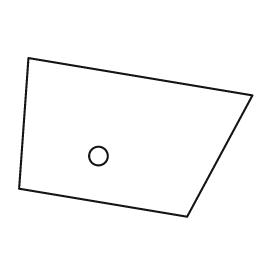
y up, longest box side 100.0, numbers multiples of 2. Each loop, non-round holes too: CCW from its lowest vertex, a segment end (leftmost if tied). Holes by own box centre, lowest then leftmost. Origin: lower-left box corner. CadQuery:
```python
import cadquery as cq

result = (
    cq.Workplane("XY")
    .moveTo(72.0, 0.0)
    .lineTo(100.0, 52.0)
    .lineTo(4.0, 68.0)
    .lineTo(0.0, 12.0)
    .close()
    .moveTo(34.0, 26.0)
    .circle(4.0)
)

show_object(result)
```